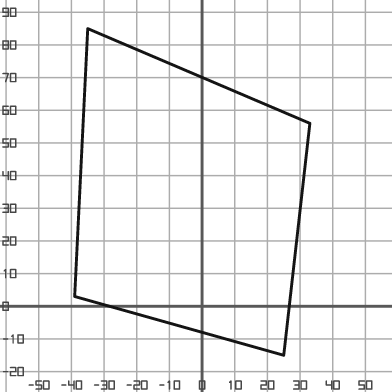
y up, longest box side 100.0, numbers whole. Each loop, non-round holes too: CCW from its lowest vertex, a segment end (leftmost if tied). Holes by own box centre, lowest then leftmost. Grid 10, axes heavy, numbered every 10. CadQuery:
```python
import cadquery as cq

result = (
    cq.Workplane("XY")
    .moveTo(25.0, -15.0)
    .lineTo(33.0, 56.0)
    .lineTo(-35.0, 85.0)
    .lineTo(-39.0, 3.0)
    .close()
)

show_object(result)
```